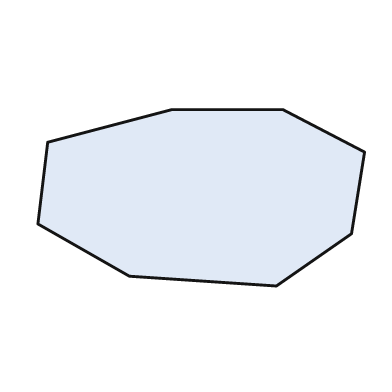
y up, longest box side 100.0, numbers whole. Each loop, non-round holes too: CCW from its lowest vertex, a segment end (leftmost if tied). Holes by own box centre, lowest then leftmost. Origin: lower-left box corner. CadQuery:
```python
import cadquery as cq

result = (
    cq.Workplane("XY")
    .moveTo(73.0, 0.0)
    .lineTo(96.0, 16.0)
    .lineTo(100.0, 41.0)
    .lineTo(75.0, 54.0)
    .lineTo(41.0, 54.0)
    .lineTo(3.0, 44.0)
    .lineTo(0.0, 19.0)
    .lineTo(28.0, 3.0)
    .close()
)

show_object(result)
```